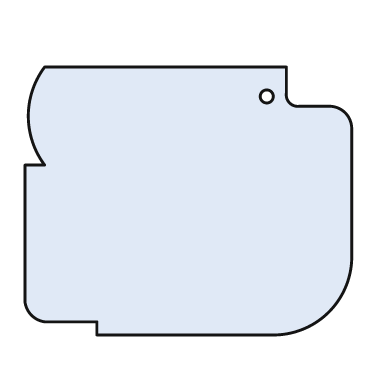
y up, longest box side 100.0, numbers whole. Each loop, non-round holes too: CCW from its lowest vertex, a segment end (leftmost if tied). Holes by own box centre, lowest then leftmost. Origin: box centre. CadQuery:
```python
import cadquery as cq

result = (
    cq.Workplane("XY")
    .moveTo(-28.0, -41.0)
    .lineTo(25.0, -41.0)
    .threePointArc((43.0, -34.0), (50.0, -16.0))
    .lineTo(50.0, 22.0)
    .threePointArc((48.0, 27.0), (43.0, 29.0))
    .lineTo(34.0, 29.0)
    .threePointArc((31.0, 30.0), (30.0, 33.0))
    .lineTo(30.0, 41.0)
    .lineTo(-44.0, 41.0)
    .threePointArc((-49.0, 26.0), (-44.0, 11.0))
    .lineTo(-50.0, 11.0)
    .lineTo(-50.0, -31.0)
    .threePointArc((-48.0, -35.0), (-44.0, -37.0))
    .lineTo(-28.0, -37.0)
    .close()
    .moveTo(24.0, 32.0)
    .circle(2.0)
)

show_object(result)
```